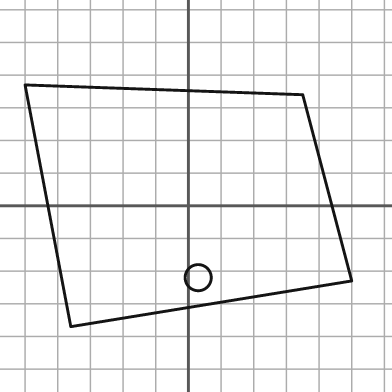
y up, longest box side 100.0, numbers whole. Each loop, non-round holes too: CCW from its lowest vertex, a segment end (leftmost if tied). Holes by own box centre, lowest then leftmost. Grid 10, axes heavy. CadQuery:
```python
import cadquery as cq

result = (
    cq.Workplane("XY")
    .moveTo(-36.0, -37.0)
    .lineTo(50.0, -23.0)
    .lineTo(35.0, 34.0)
    .lineTo(-50.0, 37.0)
    .close()
    .moveTo(3.0, -22.0)
    .circle(4.0)
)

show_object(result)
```